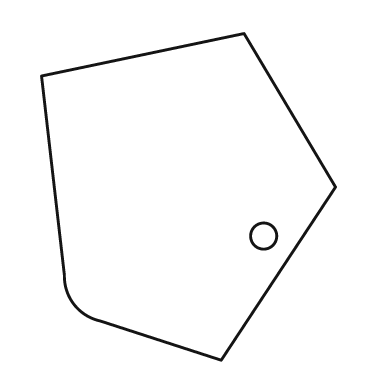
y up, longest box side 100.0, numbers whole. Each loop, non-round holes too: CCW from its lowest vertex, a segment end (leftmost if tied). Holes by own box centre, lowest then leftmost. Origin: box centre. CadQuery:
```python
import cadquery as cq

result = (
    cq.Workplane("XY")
    .moveTo(10.0, -50.0)
    .lineTo(45.0, 3.0)
    .lineTo(17.0, 50.0)
    .lineTo(-45.0, 37.0)
    .lineTo(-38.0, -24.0)
    .threePointArc((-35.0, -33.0), (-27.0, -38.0))
    .close()
    .moveTo(23.0, -12.0)
    .circle(4.0)
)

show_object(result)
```